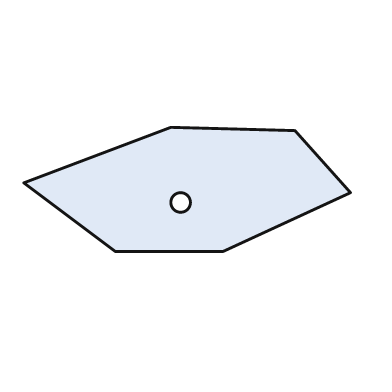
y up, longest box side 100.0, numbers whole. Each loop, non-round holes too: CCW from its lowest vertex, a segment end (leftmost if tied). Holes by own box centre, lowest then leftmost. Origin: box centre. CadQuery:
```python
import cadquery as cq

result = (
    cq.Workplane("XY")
    .moveTo(-22.0, -19.0)
    .lineTo(11.0, -19.0)
    .lineTo(50.0, -1.0)
    .lineTo(33.0, 18.0)
    .lineTo(-5.0, 19.0)
    .lineTo(-50.0, 2.0)
    .close()
    .moveTo(-2.0, -4.0)
    .circle(3.0)
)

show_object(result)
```